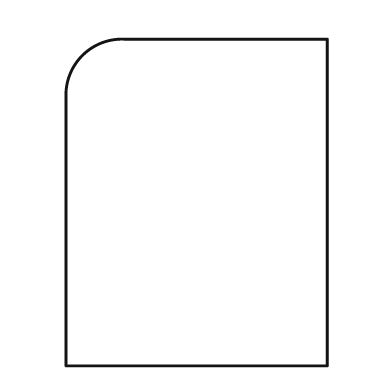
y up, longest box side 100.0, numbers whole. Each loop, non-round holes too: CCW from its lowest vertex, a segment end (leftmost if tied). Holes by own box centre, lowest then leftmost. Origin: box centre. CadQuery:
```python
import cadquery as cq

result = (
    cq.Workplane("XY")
    .moveTo(-40.0, -50.0)
    .lineTo(40.0, -50.0)
    .lineTo(40.0, 50.0)
    .lineTo(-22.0, 50.0)
    .threePointArc((-35.0, 45.0), (-40.0, 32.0))
    .close()
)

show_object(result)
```